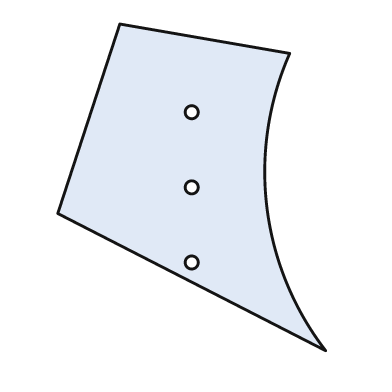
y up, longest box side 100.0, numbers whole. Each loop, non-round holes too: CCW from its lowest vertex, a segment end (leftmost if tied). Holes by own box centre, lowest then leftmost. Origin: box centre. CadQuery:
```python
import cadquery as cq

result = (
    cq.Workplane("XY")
    .moveTo(41.0, -50.0)
    .threePointArc((23.0, -6.0), (30.0, 41.0))
    .lineTo(-22.0, 50.0)
    .lineTo(-41.0, -8.0)
    .close()
    .moveTo(0.0, -23.0)
    .circle(2.0)
    .moveTo(0.0, 0.0)
    .circle(2.0)
    .moveTo(0.0, 23.0)
    .circle(2.0)
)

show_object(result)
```